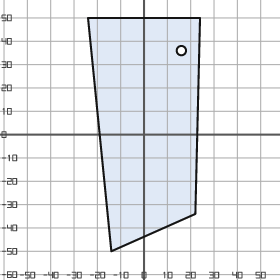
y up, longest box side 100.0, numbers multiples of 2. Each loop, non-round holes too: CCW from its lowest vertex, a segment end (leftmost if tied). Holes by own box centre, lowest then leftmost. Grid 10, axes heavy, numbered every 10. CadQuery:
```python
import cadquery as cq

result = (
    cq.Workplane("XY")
    .moveTo(-14.0, -50.0)
    .lineTo(22.0, -34.0)
    .lineTo(24.0, 50.0)
    .lineTo(-24.0, 50.0)
    .close()
    .moveTo(16.0, 36.0)
    .circle(2.0)
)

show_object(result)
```